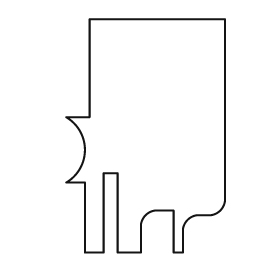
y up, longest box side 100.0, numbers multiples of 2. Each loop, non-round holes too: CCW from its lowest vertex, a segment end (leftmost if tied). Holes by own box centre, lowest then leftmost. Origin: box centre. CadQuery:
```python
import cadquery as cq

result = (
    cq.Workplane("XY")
    .moveTo(-26.0, -50.0)
    .lineTo(-18.0, -50.0)
    .lineTo(-18.0, -16.0)
    .lineTo(-12.0, -16.0)
    .lineTo(-12.0, -50.0)
    .lineTo(-2.0, -50.0)
    .lineTo(-2.0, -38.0)
    .threePointArc((0.0, -34.0), (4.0, -32.0))
    .lineTo(12.0, -32.0)
    .lineTo(12.0, -50.0)
    .lineTo(16.0, -50.0)
    .lineTo(16.0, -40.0)
    .threePointArc((18.0, -36.0), (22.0, -34.0))
    .lineTo(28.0, -34.0)
    .threePointArc((32.0, -32.0), (34.0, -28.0))
    .lineTo(34.0, 50.0)
    .lineTo(-24.0, 50.0)
    .lineTo(-24.0, 8.0)
    .lineTo(-34.0, 8.0)
    .threePointArc((-26.0, -6.0), (-34.0, -20.0))
    .lineTo(-26.0, -20.0)
    .close()
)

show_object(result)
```